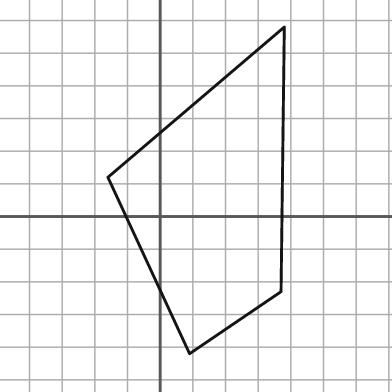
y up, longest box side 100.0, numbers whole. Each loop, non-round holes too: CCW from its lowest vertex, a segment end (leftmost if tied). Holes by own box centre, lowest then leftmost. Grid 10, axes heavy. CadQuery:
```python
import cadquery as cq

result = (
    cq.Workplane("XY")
    .moveTo(9.0, -42.0)
    .lineTo(37.0, -23.0)
    .lineTo(38.0, 58.0)
    .lineTo(-16.0, 12.0)
    .close()
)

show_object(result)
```